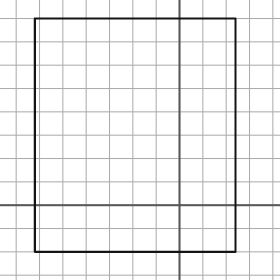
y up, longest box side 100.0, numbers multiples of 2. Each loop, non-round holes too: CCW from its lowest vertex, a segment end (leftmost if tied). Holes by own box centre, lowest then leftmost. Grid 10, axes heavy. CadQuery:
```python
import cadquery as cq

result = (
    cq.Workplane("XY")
    .moveTo(-62.0, -20.0)
    .lineTo(24.0, -20.0)
    .lineTo(24.0, 80.0)
    .lineTo(-62.0, 80.0)
    .close()
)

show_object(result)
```